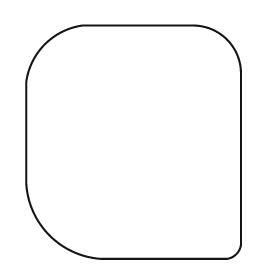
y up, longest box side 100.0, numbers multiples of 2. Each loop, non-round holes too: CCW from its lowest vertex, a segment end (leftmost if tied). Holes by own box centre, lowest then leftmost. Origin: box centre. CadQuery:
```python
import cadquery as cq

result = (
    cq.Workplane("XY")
    .moveTo(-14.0, -50.0)
    .lineTo(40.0, -50.0)
    .threePointArc((44.0, -48.0), (46.0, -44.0))
    .lineTo(46.0, 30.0)
    .threePointArc((40.0, 44.0), (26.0, 50.0))
    .lineTo(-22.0, 50.0)
    .threePointArc((-38.0, 42.0), (-46.0, 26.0))
    .lineTo(-46.0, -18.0)
    .threePointArc((-36.0, -40.0), (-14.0, -50.0))
    .close()
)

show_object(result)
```